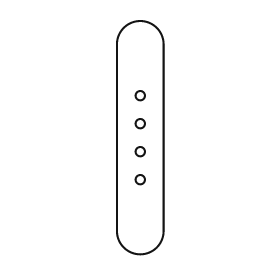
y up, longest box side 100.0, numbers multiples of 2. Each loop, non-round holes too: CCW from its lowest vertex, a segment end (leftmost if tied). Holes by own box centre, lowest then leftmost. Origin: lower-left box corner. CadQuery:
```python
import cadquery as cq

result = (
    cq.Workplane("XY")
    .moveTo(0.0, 10.0)
    .threePointArc((10.0, 0.0), (20.0, 10.0))
    .lineTo(20.0, 90.0)
    .threePointArc((10.0, 100.0), (0.0, 90.0))
    .close()
    .moveTo(10.0, 32.0)
    .circle(2.0)
    .moveTo(10.0, 44.0)
    .circle(2.0)
    .moveTo(10.0, 56.0)
    .circle(2.0)
    .moveTo(10.0, 68.0)
    .circle(2.0)
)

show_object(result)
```